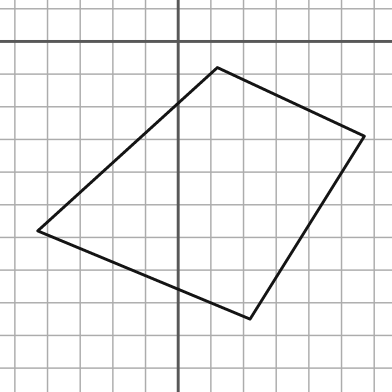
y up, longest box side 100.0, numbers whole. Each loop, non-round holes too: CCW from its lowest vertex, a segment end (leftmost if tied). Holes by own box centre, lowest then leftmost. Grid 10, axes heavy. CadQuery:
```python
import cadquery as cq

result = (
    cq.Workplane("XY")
    .moveTo(22.0, -85.0)
    .lineTo(57.0, -29.0)
    .lineTo(12.0, -8.0)
    .lineTo(-43.0, -58.0)
    .close()
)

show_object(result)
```